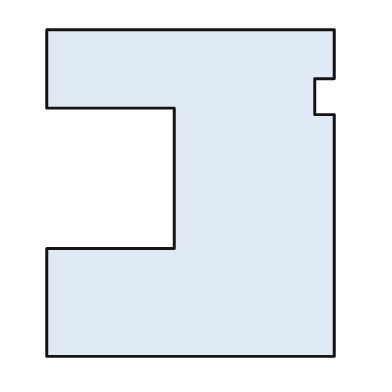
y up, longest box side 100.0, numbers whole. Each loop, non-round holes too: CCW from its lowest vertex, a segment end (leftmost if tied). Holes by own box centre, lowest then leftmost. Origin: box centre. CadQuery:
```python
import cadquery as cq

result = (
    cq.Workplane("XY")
    .moveTo(-44.0, -50.0)
    .lineTo(44.0, -50.0)
    .lineTo(44.0, 24.0)
    .lineTo(38.0, 24.0)
    .lineTo(38.0, 35.0)
    .lineTo(44.0, 35.0)
    .lineTo(44.0, 50.0)
    .lineTo(-44.0, 50.0)
    .lineTo(-44.0, 26.0)
    .lineTo(-5.0, 26.0)
    .lineTo(-5.0, -17.0)
    .lineTo(-44.0, -17.0)
    .close()
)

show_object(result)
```